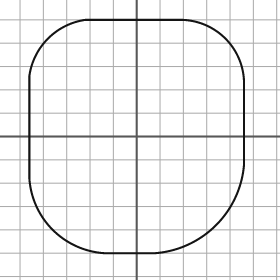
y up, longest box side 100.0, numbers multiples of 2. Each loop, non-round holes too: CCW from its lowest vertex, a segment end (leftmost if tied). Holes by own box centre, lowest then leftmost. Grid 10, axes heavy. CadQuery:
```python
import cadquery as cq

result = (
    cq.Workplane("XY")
    .moveTo(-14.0, -50.0)
    .lineTo(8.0, -50.0)
    .threePointArc((34.0, -38.0), (46.0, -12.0))
    .lineTo(46.0, 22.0)
    .threePointArc((38.0, 42.0), (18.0, 50.0))
    .lineTo(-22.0, 50.0)
    .threePointArc((-38.0, 42.0), (-46.0, 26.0))
    .lineTo(-46.0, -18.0)
    .threePointArc((-36.0, -40.0), (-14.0, -50.0))
    .close()
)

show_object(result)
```